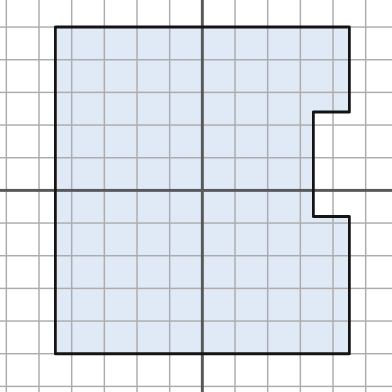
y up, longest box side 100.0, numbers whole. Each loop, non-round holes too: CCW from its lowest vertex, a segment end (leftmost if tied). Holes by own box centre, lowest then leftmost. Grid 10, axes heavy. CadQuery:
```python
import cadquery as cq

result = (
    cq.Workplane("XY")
    .moveTo(-45.0, -50.0)
    .lineTo(45.0, -50.0)
    .lineTo(45.0, -8.0)
    .lineTo(34.0, -8.0)
    .lineTo(34.0, 24.0)
    .lineTo(45.0, 24.0)
    .lineTo(45.0, 50.0)
    .lineTo(-45.0, 50.0)
    .close()
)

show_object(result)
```